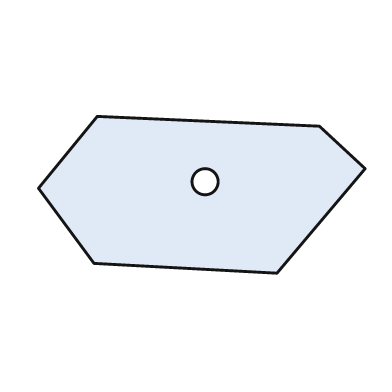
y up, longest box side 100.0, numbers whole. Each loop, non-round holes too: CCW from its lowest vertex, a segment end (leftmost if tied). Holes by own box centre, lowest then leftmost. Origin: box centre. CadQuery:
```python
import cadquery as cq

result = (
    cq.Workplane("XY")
    .moveTo(23.0, -24.0)
    .lineTo(50.0, 8.0)
    .lineTo(36.0, 21.0)
    .lineTo(-32.0, 24.0)
    .lineTo(-50.0, 2.0)
    .lineTo(-33.0, -21.0)
    .close()
    .moveTo(1.0, 4.0)
    .circle(4.0)
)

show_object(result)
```